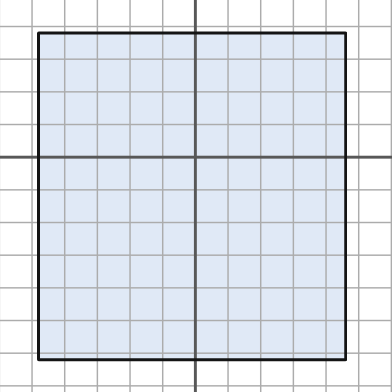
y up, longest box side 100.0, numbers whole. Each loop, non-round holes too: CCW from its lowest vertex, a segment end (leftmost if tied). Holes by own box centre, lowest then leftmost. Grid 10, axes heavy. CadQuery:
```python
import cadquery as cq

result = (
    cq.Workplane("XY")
    .moveTo(-48.0, -62.0)
    .lineTo(46.0, -62.0)
    .lineTo(46.0, 38.0)
    .lineTo(-48.0, 38.0)
    .close()
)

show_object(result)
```